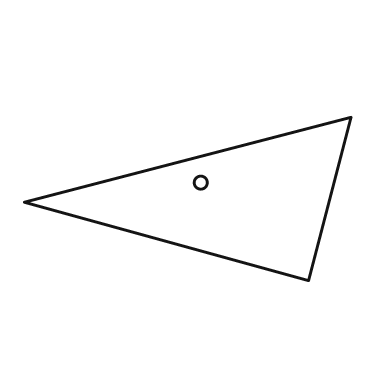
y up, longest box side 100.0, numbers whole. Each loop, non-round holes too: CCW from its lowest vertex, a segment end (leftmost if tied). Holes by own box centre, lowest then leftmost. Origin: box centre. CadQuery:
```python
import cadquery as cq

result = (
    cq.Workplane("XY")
    .moveTo(37.0, -25.0)
    .lineTo(50.0, 25.0)
    .lineTo(-50.0, -1.0)
    .close()
    .moveTo(4.0, 5.0)
    .circle(2.0)
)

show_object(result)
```